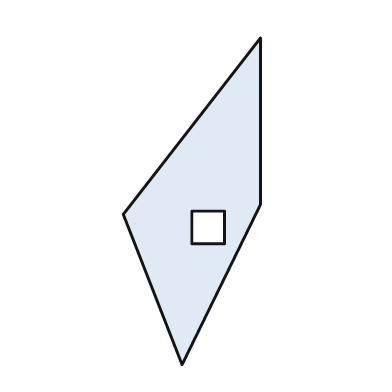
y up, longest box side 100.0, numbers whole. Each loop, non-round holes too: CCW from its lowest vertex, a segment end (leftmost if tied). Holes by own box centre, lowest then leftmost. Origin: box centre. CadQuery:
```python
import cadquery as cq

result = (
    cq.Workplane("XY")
    .moveTo(-3.0, -50.0)
    .lineTo(21.0, -1.0)
    .lineTo(21.0, 50.0)
    .lineTo(-21.0, -4.0)
    .close()
    .moveTo(0.0, -13.0)
    .lineTo(10.0, -13.0)
    .lineTo(10.0, -3.0)
    .lineTo(0.0, -3.0)
    .close()
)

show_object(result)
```